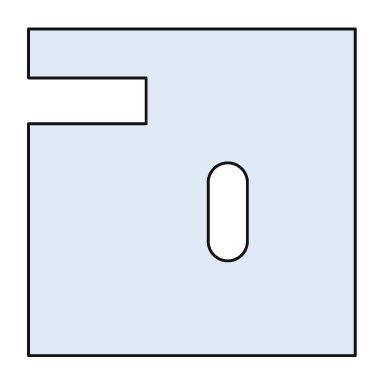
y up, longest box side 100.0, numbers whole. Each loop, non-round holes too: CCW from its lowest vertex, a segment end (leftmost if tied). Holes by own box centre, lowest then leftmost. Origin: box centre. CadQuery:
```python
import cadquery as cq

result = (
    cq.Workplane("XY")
    .moveTo(-50.0, -50.0)
    .lineTo(50.0, -50.0)
    .lineTo(50.0, 50.0)
    .lineTo(-50.0, 50.0)
    .lineTo(-50.0, 35.0)
    .lineTo(-14.0, 35.0)
    .lineTo(-14.0, 21.0)
    .lineTo(-50.0, 21.0)
    .close()
    .moveTo(5.0, -15.0)
    .threePointArc((11.0, -21.0), (17.0, -15.0))
    .lineTo(17.0, 3.0)
    .threePointArc((11.0, 9.0), (5.0, 3.0))
    .close()
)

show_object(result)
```